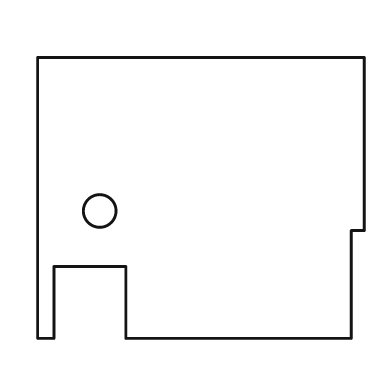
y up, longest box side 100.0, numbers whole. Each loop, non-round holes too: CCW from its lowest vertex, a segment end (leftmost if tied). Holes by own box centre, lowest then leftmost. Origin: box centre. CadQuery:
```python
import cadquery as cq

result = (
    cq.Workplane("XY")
    .moveTo(-50.0, -43.0)
    .lineTo(-45.0, -43.0)
    .lineTo(-45.0, -21.0)
    .lineTo(-23.0, -21.0)
    .lineTo(-23.0, -43.0)
    .lineTo(46.0, -43.0)
    .lineTo(46.0, -10.0)
    .lineTo(50.0, -10.0)
    .lineTo(50.0, 43.0)
    .lineTo(-50.0, 43.0)
    .close()
    .moveTo(-31.0, -4.0)
    .circle(5.0)
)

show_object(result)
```